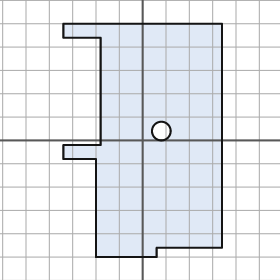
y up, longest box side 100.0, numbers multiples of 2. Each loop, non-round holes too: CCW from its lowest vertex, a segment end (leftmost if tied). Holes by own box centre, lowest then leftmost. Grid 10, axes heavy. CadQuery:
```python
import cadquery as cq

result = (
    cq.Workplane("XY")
    .moveTo(-20.0, -50.0)
    .lineTo(6.0, -50.0)
    .lineTo(6.0, -46.0)
    .lineTo(34.0, -46.0)
    .lineTo(34.0, 50.0)
    .lineTo(-34.0, 50.0)
    .lineTo(-34.0, 44.0)
    .lineTo(-18.0, 44.0)
    .lineTo(-18.0, -2.0)
    .lineTo(-34.0, -2.0)
    .lineTo(-34.0, -8.0)
    .lineTo(-20.0, -8.0)
    .close()
    .moveTo(8.0, 4.0)
    .circle(4.0)
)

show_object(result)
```